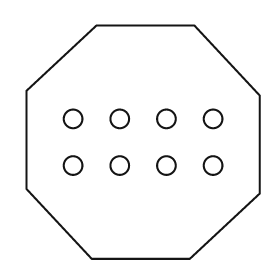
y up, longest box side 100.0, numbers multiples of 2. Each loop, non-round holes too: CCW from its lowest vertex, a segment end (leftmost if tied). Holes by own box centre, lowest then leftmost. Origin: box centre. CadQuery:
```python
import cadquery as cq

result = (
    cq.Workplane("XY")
    .moveTo(-22.0, -50.0)
    .lineTo(20.0, -50.0)
    .lineTo(50.0, -22.0)
    .lineTo(50.0, 20.0)
    .lineTo(22.0, 50.0)
    .lineTo(-20.0, 50.0)
    .lineTo(-50.0, 22.0)
    .lineTo(-50.0, -20.0)
    .close()
    .moveTo(-30.0, -10.0)
    .circle(4.0)
    .moveTo(-10.0, -10.0)
    .circle(4.0)
    .moveTo(10.0, -10.0)
    .circle(4.0)
    .moveTo(30.0, -10.0)
    .circle(4.0)
    .moveTo(-30.0, 10.0)
    .circle(4.0)
    .moveTo(-10.0, 10.0)
    .circle(4.0)
    .moveTo(10.0, 10.0)
    .circle(4.0)
    .moveTo(30.0, 10.0)
    .circle(4.0)
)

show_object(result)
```